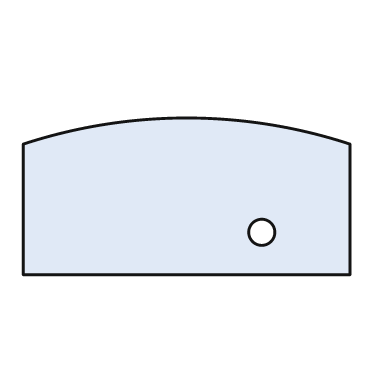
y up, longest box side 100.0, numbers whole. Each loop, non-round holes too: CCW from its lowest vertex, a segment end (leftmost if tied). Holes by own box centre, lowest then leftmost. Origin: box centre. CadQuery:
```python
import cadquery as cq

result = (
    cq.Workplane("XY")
    .moveTo(-50.0, -24.0)
    .lineTo(50.0, -24.0)
    .lineTo(50.0, 16.0)
    .threePointArc((0.0, 24.0), (-50.0, 16.0))
    .close()
    .moveTo(23.0, -11.0)
    .circle(4.0)
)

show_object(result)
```